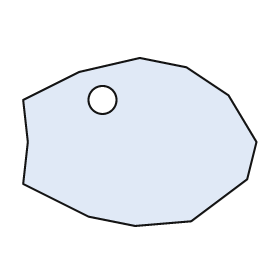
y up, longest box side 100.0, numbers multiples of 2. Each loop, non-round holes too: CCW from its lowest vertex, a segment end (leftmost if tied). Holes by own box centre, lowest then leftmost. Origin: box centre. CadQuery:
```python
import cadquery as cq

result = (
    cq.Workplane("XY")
    .moveTo(-2.0, -36.0)
    .lineTo(22.0, -34.0)
    .lineTo(46.0, -16.0)
    .lineTo(50.0, 0.0)
    .lineTo(38.0, 20.0)
    .lineTo(20.0, 32.0)
    .lineTo(0.0, 36.0)
    .lineTo(-26.0, 30.0)
    .lineTo(-50.0, 18.0)
    .lineTo(-48.0, 0.0)
    .lineTo(-50.0, -18.0)
    .lineTo(-22.0, -32.0)
    .close()
    .moveTo(-16.0, 18.0)
    .circle(6.0)
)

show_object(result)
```